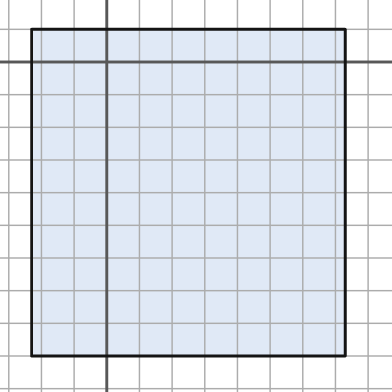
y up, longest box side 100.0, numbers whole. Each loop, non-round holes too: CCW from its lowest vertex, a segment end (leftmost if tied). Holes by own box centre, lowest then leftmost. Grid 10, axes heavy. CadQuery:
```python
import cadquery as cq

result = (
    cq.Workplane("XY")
    .moveTo(-23.0, -90.0)
    .lineTo(73.0, -90.0)
    .lineTo(73.0, 10.0)
    .lineTo(-23.0, 10.0)
    .close()
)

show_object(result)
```